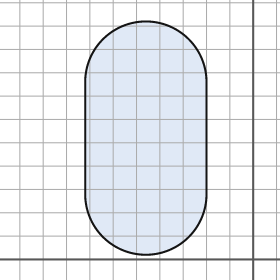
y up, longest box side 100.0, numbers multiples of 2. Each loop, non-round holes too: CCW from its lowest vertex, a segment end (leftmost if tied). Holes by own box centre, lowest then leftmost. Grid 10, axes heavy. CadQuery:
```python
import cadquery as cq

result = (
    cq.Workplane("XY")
    .moveTo(-72.0, 28.0)
    .threePointArc((-46.0, 2.0), (-20.0, 28.0))
    .lineTo(-20.0, 76.0)
    .threePointArc((-46.0, 102.0), (-72.0, 76.0))
    .close()
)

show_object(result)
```